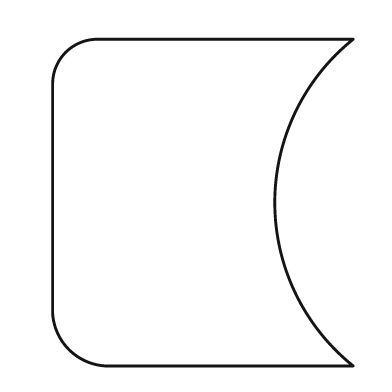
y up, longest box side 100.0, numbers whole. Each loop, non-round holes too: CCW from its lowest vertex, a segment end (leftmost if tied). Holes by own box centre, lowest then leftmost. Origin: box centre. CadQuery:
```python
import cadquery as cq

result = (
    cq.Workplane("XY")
    .moveTo(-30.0, -50.0)
    .lineTo(46.0, -50.0)
    .threePointArc((22.0, 0.0), (46.0, 50.0))
    .lineTo(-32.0, 50.0)
    .threePointArc((-42.0, 46.0), (-46.0, 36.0))
    .lineTo(-46.0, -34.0)
    .threePointArc((-41.0, -45.0), (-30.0, -50.0))
    .close()
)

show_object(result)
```